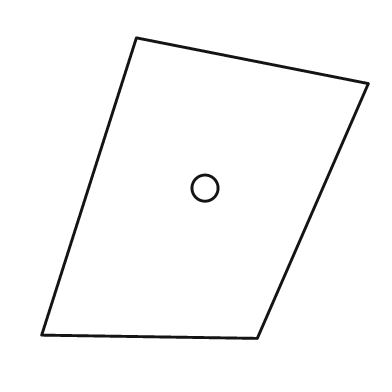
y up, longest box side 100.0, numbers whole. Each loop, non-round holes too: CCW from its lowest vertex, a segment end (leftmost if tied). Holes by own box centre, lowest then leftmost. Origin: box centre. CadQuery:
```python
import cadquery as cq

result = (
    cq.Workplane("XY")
    .moveTo(16.0, -46.0)
    .lineTo(50.0, 32.0)
    .lineTo(-21.0, 46.0)
    .lineTo(-50.0, -45.0)
    .close()
    .moveTo(0.0, 0.0)
    .circle(4.0)
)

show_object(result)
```